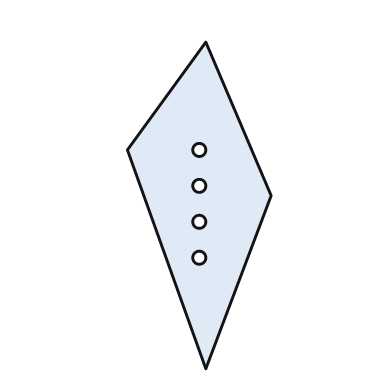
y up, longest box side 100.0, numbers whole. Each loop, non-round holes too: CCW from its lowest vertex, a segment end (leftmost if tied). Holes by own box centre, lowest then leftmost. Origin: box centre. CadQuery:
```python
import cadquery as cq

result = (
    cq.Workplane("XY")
    .moveTo(2.0, -50.0)
    .lineTo(22.0, 3.0)
    .lineTo(2.0, 50.0)
    .lineTo(-22.0, 17.0)
    .close()
    .moveTo(0.0, -16.0)
    .circle(2.0)
    .moveTo(0.0, -5.0)
    .circle(2.0)
    .moveTo(0.0, 6.0)
    .circle(2.0)
    .moveTo(0.0, 17.0)
    .circle(2.0)
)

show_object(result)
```